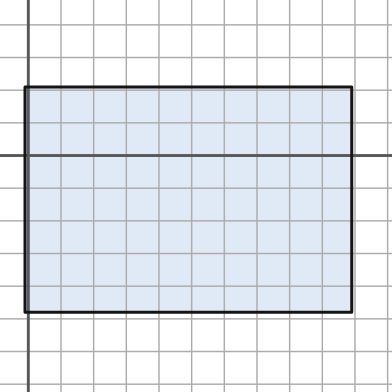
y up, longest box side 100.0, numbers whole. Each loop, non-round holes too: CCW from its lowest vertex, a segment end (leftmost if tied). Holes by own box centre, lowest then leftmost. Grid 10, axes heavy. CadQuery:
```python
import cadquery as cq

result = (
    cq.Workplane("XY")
    .moveTo(-1.0, -48.0)
    .lineTo(99.0, -48.0)
    .lineTo(99.0, 21.0)
    .lineTo(-1.0, 21.0)
    .close()
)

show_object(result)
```